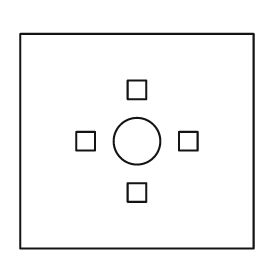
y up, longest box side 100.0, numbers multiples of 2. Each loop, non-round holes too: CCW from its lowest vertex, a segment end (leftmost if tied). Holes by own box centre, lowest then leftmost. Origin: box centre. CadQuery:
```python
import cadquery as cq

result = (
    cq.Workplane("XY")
    .moveTo(-50.0, -46.0)
    .lineTo(50.0, -46.0)
    .lineTo(50.0, 46.0)
    .lineTo(-50.0, 46.0)
    .close()
    .moveTo(-4.0, -26.0)
    .lineTo(4.0, -26.0)
    .lineTo(4.0, -18.0)
    .lineTo(-4.0, -18.0)
    .close()
    .moveTo(-26.0, -4.0)
    .lineTo(-18.0, -4.0)
    .lineTo(-18.0, 4.0)
    .lineTo(-26.0, 4.0)
    .close()
    .moveTo(0.0, 0.0)
    .circle(10.0)
    .moveTo(18.0, -4.0)
    .lineTo(26.0, -4.0)
    .lineTo(26.0, 4.0)
    .lineTo(18.0, 4.0)
    .close()
    .moveTo(-4.0, 18.0)
    .lineTo(4.0, 18.0)
    .lineTo(4.0, 26.0)
    .lineTo(-4.0, 26.0)
    .close()
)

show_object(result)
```